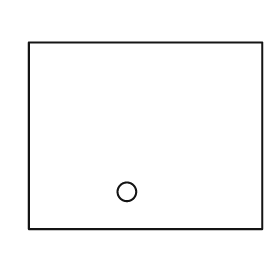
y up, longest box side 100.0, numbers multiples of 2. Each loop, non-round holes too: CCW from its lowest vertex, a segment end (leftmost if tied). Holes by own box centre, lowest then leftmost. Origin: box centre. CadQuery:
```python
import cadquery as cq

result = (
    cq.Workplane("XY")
    .moveTo(-50.0, -40.0)
    .lineTo(50.0, -40.0)
    .lineTo(50.0, 40.0)
    .lineTo(-50.0, 40.0)
    .close()
    .moveTo(-8.0, -24.0)
    .circle(4.0)
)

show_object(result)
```